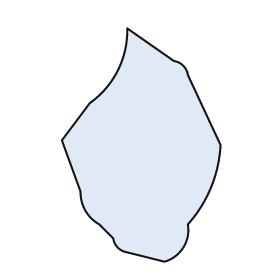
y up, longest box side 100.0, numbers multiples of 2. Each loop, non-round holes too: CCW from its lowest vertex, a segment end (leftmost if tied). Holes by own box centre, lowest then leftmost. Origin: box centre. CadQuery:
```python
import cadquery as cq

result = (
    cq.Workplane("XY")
    .moveTo(10.0, -50.0)
    .threePointArc((18.0, -44.0), (20.0, -34.0))
    .threePointArc((30.0, -18.0), (34.0, 0.0))
    .lineTo(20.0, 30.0)
    .threePointArc((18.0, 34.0), (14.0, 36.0))
    .lineTo(-6.0, 50.0)
    .threePointArc((-10.0, 32.0), (-22.0, 18.0))
    .lineTo(-34.0, 2.0)
    .lineTo(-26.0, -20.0)
    .threePointArc((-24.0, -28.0), (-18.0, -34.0))
    .lineTo(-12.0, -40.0)
    .threePointArc((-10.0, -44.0), (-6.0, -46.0))
    .close()
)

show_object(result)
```